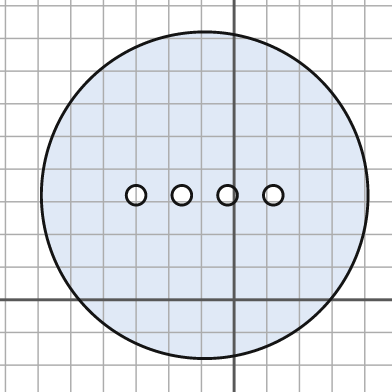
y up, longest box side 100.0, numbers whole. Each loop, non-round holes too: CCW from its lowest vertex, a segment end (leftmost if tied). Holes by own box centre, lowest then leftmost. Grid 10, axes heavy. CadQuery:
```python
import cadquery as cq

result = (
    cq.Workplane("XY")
    .moveTo(-9.0, 32.0)
    .circle(50.0)
    .moveTo(-30.0, 32.0)
    .circle(3.0)
    .moveTo(-16.0, 32.0)
    .circle(3.0)
    .moveTo(-2.0, 32.0)
    .circle(3.0)
    .moveTo(12.0, 32.0)
    .circle(3.0)
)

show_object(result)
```